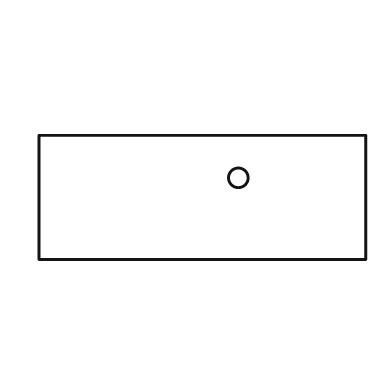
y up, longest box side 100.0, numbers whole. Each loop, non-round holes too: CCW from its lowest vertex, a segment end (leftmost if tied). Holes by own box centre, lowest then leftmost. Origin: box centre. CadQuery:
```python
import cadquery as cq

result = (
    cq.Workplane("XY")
    .moveTo(-50.0, -19.0)
    .lineTo(50.0, -19.0)
    .lineTo(50.0, 19.0)
    .lineTo(-50.0, 19.0)
    .close()
    .moveTo(11.0, 6.0)
    .circle(3.0)
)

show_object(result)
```